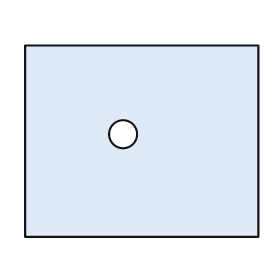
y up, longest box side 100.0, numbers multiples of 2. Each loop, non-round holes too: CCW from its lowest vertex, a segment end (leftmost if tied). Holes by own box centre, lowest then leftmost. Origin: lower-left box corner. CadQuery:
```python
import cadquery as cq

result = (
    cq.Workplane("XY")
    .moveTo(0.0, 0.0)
    .lineTo(100.0, 0.0)
    .lineTo(100.0, 82.0)
    .lineTo(0.0, 82.0)
    .close()
    .moveTo(42.0, 44.0)
    .circle(6.0)
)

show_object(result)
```